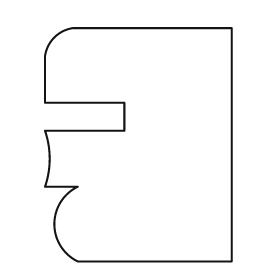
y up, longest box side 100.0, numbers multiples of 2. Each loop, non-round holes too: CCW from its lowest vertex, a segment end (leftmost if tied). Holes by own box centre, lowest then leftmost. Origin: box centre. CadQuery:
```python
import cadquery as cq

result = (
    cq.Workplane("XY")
    .moveTo(-26.0, -50.0)
    .lineTo(40.0, -50.0)
    .lineTo(40.0, 50.0)
    .lineTo(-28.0, 50.0)
    .threePointArc((-36.0, 46.0), (-40.0, 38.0))
    .lineTo(-40.0, 18.0)
    .lineTo(-6.0, 18.0)
    .lineTo(-6.0, 6.0)
    .lineTo(-40.0, 6.0)
    .threePointArc((-38.0, -6.0), (-40.0, -18.0))
    .lineTo(-26.0, -18.0)
    .threePointArc((-36.0, -34.0), (-26.0, -50.0))
    .close()
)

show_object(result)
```